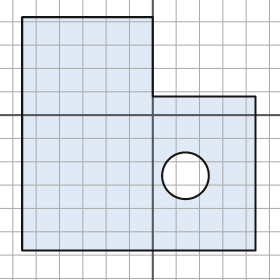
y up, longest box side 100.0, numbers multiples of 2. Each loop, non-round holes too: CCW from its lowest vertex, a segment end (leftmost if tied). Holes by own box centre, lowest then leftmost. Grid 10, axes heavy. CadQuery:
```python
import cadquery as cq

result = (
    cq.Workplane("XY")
    .moveTo(-56.0, -58.0)
    .lineTo(44.0, -58.0)
    .lineTo(44.0, 8.0)
    .lineTo(0.0, 8.0)
    .lineTo(0.0, 42.0)
    .lineTo(-56.0, 42.0)
    .close()
    .moveTo(14.0, -26.0)
    .circle(10.0)
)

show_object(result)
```